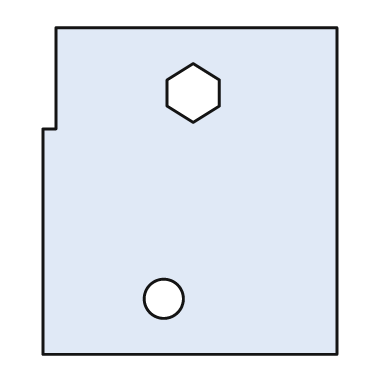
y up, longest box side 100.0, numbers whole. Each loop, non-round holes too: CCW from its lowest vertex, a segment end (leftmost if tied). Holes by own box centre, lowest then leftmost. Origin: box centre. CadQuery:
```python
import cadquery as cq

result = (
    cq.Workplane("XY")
    .moveTo(-45.0, -50.0)
    .lineTo(45.0, -50.0)
    .lineTo(45.0, 50.0)
    .lineTo(-41.0, 50.0)
    .lineTo(-41.0, 19.0)
    .lineTo(-45.0, 19.0)
    .close()
    .moveTo(-8.0, -33.0)
    .circle(6.0)
    .moveTo(1.0, 21.0)
    .lineTo(9.0, 26.0)
    .lineTo(9.0, 34.0)
    .lineTo(1.0, 39.0)
    .lineTo(-7.0, 34.0)
    .lineTo(-7.0, 26.0)
    .close()
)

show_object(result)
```